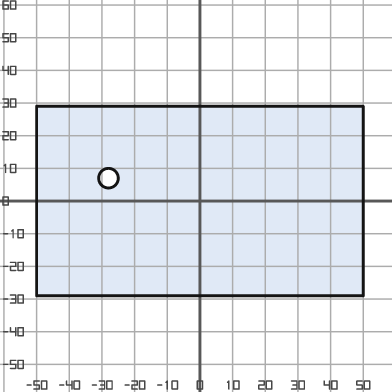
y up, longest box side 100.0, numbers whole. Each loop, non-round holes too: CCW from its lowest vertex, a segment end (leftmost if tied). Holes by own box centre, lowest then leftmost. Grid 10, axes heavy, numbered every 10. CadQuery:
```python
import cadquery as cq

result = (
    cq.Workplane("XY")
    .moveTo(-50.0, -29.0)
    .lineTo(50.0, -29.0)
    .lineTo(50.0, 29.0)
    .lineTo(-50.0, 29.0)
    .close()
    .moveTo(-28.0, 7.0)
    .circle(3.0)
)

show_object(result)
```